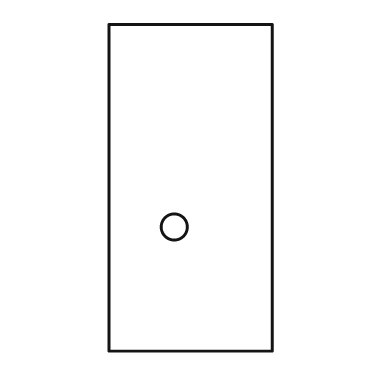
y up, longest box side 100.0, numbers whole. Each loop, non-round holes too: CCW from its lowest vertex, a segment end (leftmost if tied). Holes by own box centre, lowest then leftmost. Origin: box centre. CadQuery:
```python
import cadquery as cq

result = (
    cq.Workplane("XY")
    .moveTo(-25.0, -50.0)
    .lineTo(25.0, -50.0)
    .lineTo(25.0, 50.0)
    .lineTo(-25.0, 50.0)
    .close()
    .moveTo(-5.0, -12.0)
    .circle(4.0)
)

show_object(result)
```